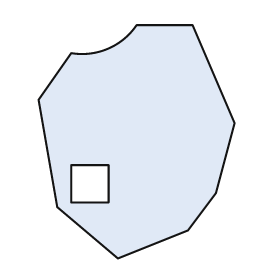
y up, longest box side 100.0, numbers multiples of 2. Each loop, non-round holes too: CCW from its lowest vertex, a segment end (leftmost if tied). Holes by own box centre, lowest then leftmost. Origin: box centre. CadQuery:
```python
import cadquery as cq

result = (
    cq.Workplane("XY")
    .moveTo(-8.0, -50.0)
    .lineTo(22.0, -38.0)
    .lineTo(34.0, -22.0)
    .lineTo(42.0, 8.0)
    .lineTo(24.0, 50.0)
    .lineTo(0.0, 50.0)
    .threePointArc((-12.0, 40.0), (-28.0, 38.0))
    .lineTo(-42.0, 18.0)
    .lineTo(-34.0, -28.0)
    .close()
    .moveTo(-28.0, -26.0)
    .lineTo(-12.0, -26.0)
    .lineTo(-12.0, -10.0)
    .lineTo(-28.0, -10.0)
    .close()
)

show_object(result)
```